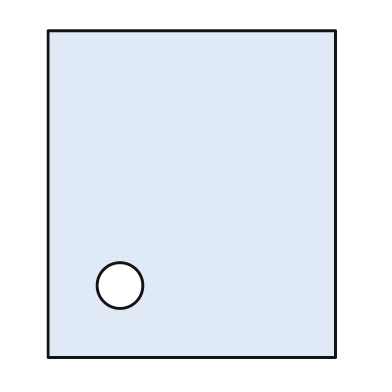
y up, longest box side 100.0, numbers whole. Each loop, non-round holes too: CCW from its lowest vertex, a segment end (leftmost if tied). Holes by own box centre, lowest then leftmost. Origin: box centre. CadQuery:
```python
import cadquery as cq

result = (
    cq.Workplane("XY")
    .moveTo(-44.0, -50.0)
    .lineTo(44.0, -50.0)
    .lineTo(44.0, 50.0)
    .lineTo(-44.0, 50.0)
    .close()
    .moveTo(-22.0, -28.0)
    .circle(7.0)
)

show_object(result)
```